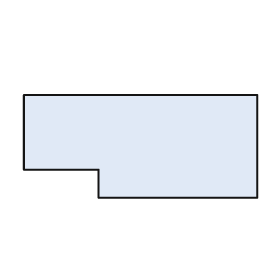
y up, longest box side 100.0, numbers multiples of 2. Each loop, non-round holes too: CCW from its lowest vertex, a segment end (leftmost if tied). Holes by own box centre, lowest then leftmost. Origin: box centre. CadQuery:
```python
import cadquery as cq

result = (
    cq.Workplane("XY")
    .moveTo(-18.0, -22.0)
    .lineTo(50.0, -22.0)
    .lineTo(50.0, 22.0)
    .lineTo(-50.0, 22.0)
    .lineTo(-50.0, -10.0)
    .lineTo(-18.0, -10.0)
    .close()
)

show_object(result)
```